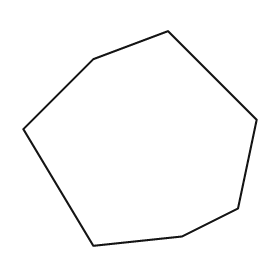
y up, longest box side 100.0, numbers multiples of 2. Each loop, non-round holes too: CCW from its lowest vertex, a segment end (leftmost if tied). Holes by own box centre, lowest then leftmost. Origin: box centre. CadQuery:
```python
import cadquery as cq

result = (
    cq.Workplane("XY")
    .moveTo(-20.0, -46.0)
    .lineTo(18.0, -42.0)
    .lineTo(42.0, -30.0)
    .lineTo(50.0, 8.0)
    .lineTo(12.0, 46.0)
    .lineTo(-20.0, 34.0)
    .lineTo(-50.0, 4.0)
    .close()
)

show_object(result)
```